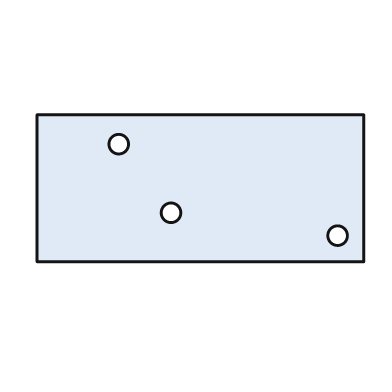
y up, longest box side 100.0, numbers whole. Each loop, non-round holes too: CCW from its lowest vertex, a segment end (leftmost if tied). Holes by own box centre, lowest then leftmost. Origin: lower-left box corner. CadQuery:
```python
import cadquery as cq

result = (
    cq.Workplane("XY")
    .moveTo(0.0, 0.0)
    .lineTo(100.0, 0.0)
    .lineTo(100.0, 45.0)
    .lineTo(0.0, 45.0)
    .close()
    .moveTo(92.0, 8.0)
    .circle(3.0)
    .moveTo(41.0, 15.0)
    .circle(3.0)
    .moveTo(25.0, 36.0)
    .circle(3.0)
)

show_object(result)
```